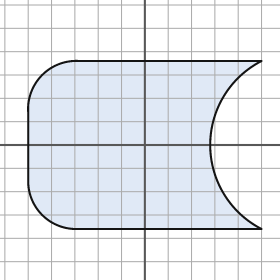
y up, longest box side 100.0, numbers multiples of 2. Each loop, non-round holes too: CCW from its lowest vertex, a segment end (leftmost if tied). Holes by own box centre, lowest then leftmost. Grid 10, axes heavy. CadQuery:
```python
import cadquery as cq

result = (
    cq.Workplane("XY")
    .moveTo(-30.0, -36.0)
    .lineTo(50.0, -36.0)
    .threePointArc((28.0, 0.0), (50.0, 36.0))
    .lineTo(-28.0, 36.0)
    .threePointArc((-44.0, 30.0), (-50.0, 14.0))
    .lineTo(-50.0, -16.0)
    .threePointArc((-44.0, -30.0), (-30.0, -36.0))
    .close()
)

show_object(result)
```